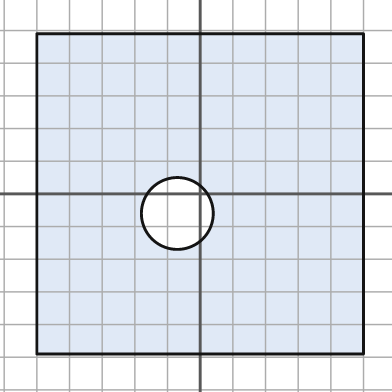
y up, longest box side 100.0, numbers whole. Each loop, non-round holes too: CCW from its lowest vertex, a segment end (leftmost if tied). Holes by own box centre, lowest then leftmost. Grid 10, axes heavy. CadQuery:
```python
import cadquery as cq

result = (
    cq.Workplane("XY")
    .moveTo(-50.0, -49.0)
    .lineTo(50.0, -49.0)
    .lineTo(50.0, 49.0)
    .lineTo(-50.0, 49.0)
    .close()
    .moveTo(-7.0, -6.0)
    .circle(11.0)
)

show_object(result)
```